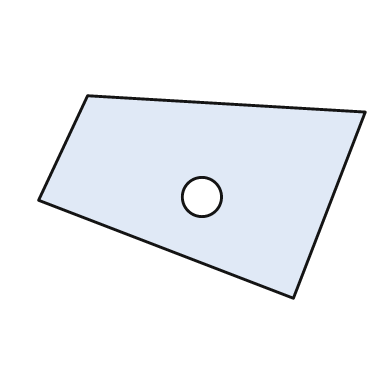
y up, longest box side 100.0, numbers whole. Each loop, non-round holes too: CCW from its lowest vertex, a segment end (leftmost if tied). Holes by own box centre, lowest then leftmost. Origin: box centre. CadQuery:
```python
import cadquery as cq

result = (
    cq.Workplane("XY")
    .moveTo(28.0, -31.0)
    .lineTo(50.0, 26.0)
    .lineTo(-35.0, 31.0)
    .lineTo(-50.0, -1.0)
    .close()
    .moveTo(0.0, 0.0)
    .circle(6.0)
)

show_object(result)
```